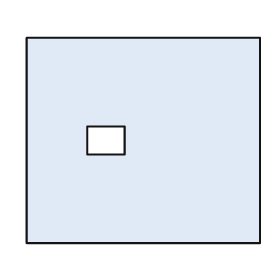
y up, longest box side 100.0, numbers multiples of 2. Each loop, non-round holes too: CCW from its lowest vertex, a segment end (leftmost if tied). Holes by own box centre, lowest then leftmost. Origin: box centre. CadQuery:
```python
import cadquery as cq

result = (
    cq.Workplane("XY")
    .moveTo(-50.0, -44.0)
    .lineTo(50.0, -44.0)
    .lineTo(50.0, 44.0)
    .lineTo(-50.0, 44.0)
    .close()
    .moveTo(-24.0, -6.0)
    .lineTo(-8.0, -6.0)
    .lineTo(-8.0, 6.0)
    .lineTo(-24.0, 6.0)
    .close()
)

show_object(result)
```